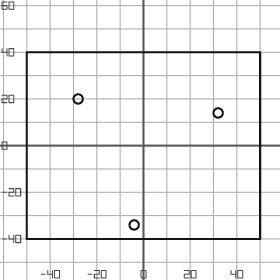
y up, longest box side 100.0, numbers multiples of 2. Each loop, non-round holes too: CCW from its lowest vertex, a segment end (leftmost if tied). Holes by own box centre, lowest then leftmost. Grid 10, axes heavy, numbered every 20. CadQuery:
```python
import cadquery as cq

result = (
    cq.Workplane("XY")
    .moveTo(-50.0, -40.0)
    .lineTo(50.0, -40.0)
    .lineTo(50.0, 40.0)
    .lineTo(-50.0, 40.0)
    .close()
    .moveTo(-4.0, -34.0)
    .circle(2.0)
    .moveTo(32.0, 14.0)
    .circle(2.0)
    .moveTo(-28.0, 20.0)
    .circle(2.0)
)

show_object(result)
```